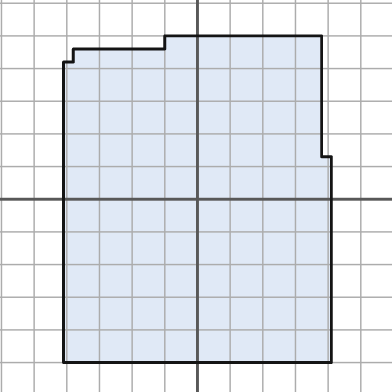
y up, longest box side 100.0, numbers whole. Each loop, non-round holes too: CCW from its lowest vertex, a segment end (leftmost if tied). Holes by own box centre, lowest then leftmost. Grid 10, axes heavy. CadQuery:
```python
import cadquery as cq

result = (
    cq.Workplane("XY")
    .moveTo(-41.0, -50.0)
    .lineTo(41.0, -50.0)
    .lineTo(41.0, 13.0)
    .lineTo(38.0, 13.0)
    .lineTo(38.0, 50.0)
    .lineTo(-10.0, 50.0)
    .lineTo(-10.0, 46.0)
    .lineTo(-38.0, 46.0)
    .lineTo(-38.0, 42.0)
    .lineTo(-41.0, 42.0)
    .close()
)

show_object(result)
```